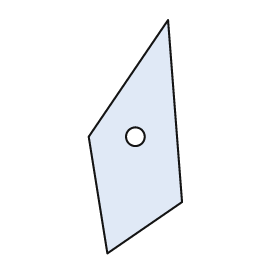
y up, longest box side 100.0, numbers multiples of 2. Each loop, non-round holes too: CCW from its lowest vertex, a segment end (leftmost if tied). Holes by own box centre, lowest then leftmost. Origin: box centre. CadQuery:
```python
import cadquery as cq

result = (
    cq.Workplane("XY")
    .moveTo(-12.0, -50.0)
    .lineTo(20.0, -28.0)
    .lineTo(14.0, 50.0)
    .lineTo(-20.0, 0.0)
    .close()
    .moveTo(0.0, 0.0)
    .circle(4.0)
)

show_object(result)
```